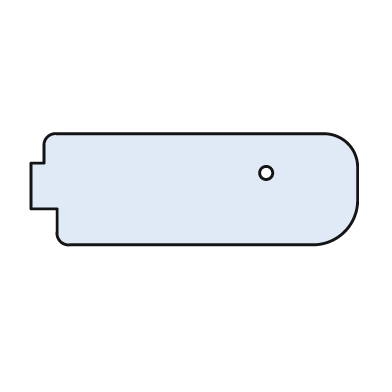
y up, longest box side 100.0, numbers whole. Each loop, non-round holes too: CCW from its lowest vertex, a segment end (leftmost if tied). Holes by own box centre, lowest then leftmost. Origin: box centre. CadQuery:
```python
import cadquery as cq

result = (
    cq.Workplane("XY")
    .moveTo(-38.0, -17.0)
    .lineTo(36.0, -17.0)
    .threePointArc((46.0, -13.0), (50.0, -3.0))
    .lineTo(50.0, 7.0)
    .threePointArc((47.0, 14.0), (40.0, 17.0))
    .lineTo(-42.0, 17.0)
    .threePointArc((-45.0, 16.0), (-46.0, 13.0))
    .lineTo(-46.0, 8.0)
    .lineTo(-50.0, 8.0)
    .lineTo(-50.0, -6.0)
    .lineTo(-42.0, -6.0)
    .lineTo(-42.0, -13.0)
    .threePointArc((-41.0, -16.0), (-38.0, -17.0))
    .close()
    .moveTo(22.0, 5.0)
    .circle(2.0)
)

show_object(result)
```